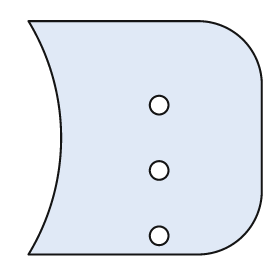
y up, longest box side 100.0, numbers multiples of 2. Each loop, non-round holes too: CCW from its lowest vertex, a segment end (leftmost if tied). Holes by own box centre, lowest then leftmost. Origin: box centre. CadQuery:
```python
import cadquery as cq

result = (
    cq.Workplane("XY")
    .moveTo(-50.0, -50.0)
    .lineTo(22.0, -50.0)
    .threePointArc((42.0, -42.0), (50.0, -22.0))
    .lineTo(50.0, 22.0)
    .threePointArc((42.0, 42.0), (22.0, 50.0))
    .lineTo(-50.0, 50.0)
    .threePointArc((-36.0, 0.0), (-50.0, -50.0))
    .close()
    .moveTo(6.0, -42.0)
    .circle(4.0)
    .moveTo(6.0, -14.0)
    .circle(4.0)
    .moveTo(6.0, 14.0)
    .circle(4.0)
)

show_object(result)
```